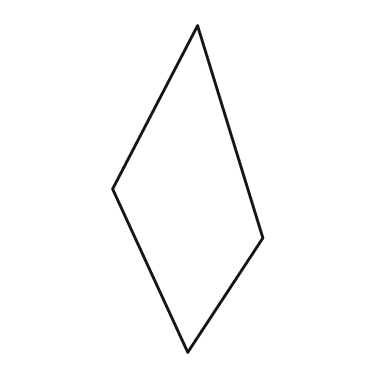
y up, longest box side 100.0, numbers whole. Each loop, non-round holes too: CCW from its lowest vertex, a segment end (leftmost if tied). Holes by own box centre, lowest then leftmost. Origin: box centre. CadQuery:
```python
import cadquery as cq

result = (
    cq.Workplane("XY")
    .moveTo(0.0, -50.0)
    .lineTo(23.0, -15.0)
    .lineTo(3.0, 50.0)
    .lineTo(-23.0, 0.0)
    .close()
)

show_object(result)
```